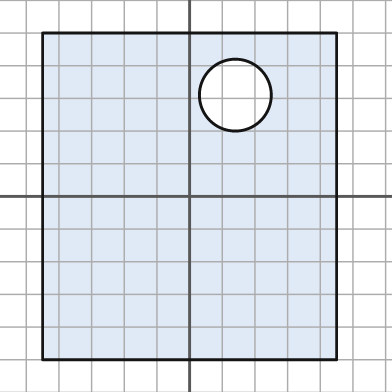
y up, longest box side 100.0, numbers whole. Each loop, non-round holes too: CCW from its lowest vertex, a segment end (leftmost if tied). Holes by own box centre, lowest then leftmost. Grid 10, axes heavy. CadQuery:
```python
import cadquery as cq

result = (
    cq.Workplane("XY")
    .moveTo(-45.0, -50.0)
    .lineTo(45.0, -50.0)
    .lineTo(45.0, 50.0)
    .lineTo(-45.0, 50.0)
    .close()
    .moveTo(14.0, 31.0)
    .circle(11.0)
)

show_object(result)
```